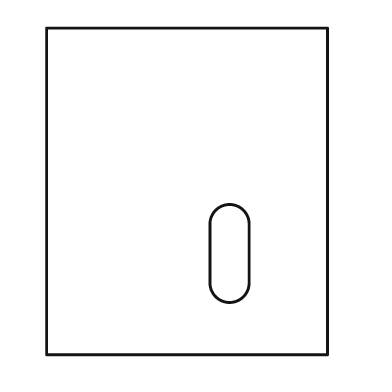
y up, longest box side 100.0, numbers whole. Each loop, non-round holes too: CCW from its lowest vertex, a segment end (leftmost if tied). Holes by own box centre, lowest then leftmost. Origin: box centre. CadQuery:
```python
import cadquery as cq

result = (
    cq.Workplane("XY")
    .moveTo(-43.0, -50.0)
    .lineTo(43.0, -50.0)
    .lineTo(43.0, 50.0)
    .lineTo(-43.0, 50.0)
    .close()
    .moveTo(7.0, -28.0)
    .threePointArc((13.0, -34.0), (19.0, -28.0))
    .lineTo(19.0, -10.0)
    .threePointArc((13.0, -4.0), (7.0, -10.0))
    .close()
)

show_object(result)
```